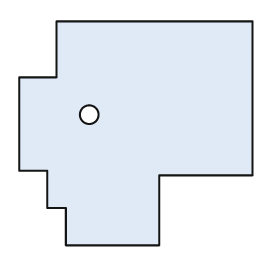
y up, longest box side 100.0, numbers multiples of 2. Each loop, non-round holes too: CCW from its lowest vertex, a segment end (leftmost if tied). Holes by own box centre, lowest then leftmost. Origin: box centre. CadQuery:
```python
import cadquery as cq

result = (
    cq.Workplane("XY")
    .moveTo(-30.0, -48.0)
    .lineTo(10.0, -48.0)
    .lineTo(10.0, -18.0)
    .lineTo(50.0, -18.0)
    .lineTo(50.0, 48.0)
    .lineTo(-34.0, 48.0)
    .lineTo(-34.0, 24.0)
    .lineTo(-50.0, 24.0)
    .lineTo(-50.0, -16.0)
    .lineTo(-38.0, -16.0)
    .lineTo(-38.0, -32.0)
    .lineTo(-30.0, -32.0)
    .close()
    .moveTo(-20.0, 8.0)
    .circle(4.0)
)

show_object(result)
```